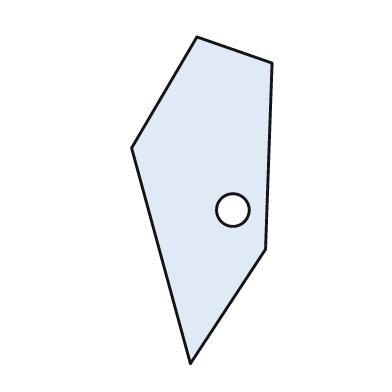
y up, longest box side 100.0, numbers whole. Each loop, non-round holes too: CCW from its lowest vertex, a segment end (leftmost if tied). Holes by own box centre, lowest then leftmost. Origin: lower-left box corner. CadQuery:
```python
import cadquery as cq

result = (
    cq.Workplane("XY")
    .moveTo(18.0, 0.0)
    .lineTo(41.0, 35.0)
    .lineTo(43.0, 92.0)
    .lineTo(20.0, 100.0)
    .lineTo(0.0, 66.0)
    .close()
    .moveTo(31.0, 47.0)
    .circle(5.0)
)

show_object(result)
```